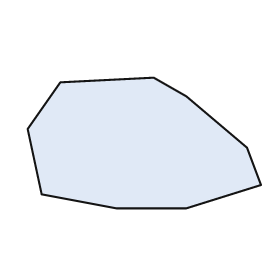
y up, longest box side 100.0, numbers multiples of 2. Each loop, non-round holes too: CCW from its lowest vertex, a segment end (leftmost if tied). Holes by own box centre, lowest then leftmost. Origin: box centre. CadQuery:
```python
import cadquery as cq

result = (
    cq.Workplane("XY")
    .moveTo(-12.0, -28.0)
    .lineTo(18.0, -28.0)
    .lineTo(50.0, -18.0)
    .lineTo(44.0, -2.0)
    .lineTo(18.0, 20.0)
    .lineTo(4.0, 28.0)
    .lineTo(-36.0, 26.0)
    .lineTo(-50.0, 6.0)
    .lineTo(-44.0, -22.0)
    .close()
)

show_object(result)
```